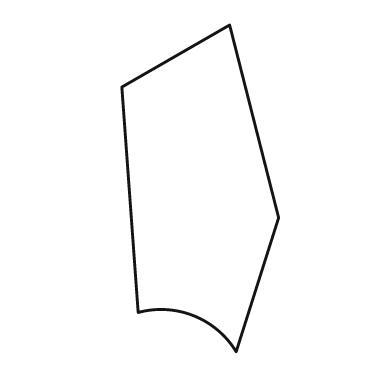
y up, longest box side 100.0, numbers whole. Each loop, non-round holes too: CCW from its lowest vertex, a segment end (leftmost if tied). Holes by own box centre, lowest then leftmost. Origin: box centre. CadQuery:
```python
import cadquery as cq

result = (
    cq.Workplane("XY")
    .moveTo(11.0, -50.0)
    .lineTo(24.0, -9.0)
    .lineTo(9.0, 50.0)
    .lineTo(-24.0, 31.0)
    .lineTo(-19.0, -38.0)
    .threePointArc((-2.0, -39.0), (11.0, -50.0))
    .close()
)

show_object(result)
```